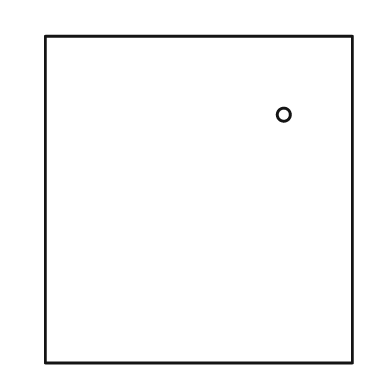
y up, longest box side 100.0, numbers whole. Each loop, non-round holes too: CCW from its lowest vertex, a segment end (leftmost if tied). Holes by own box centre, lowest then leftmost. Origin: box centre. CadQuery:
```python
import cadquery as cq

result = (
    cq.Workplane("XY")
    .moveTo(-47.0, -50.0)
    .lineTo(47.0, -50.0)
    .lineTo(47.0, 50.0)
    .lineTo(-47.0, 50.0)
    .close()
    .moveTo(26.0, 26.0)
    .circle(2.0)
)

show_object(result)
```